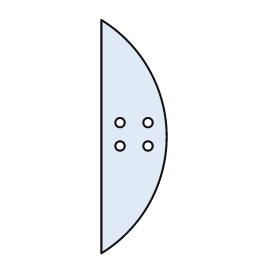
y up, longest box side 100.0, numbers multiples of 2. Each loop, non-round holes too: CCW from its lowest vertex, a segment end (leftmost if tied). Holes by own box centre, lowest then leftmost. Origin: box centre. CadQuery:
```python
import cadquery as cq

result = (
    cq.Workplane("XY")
    .moveTo(-14.0, -50.0)
    .threePointArc((14.0, 0.0), (-14.0, 50.0))
    .close()
    .moveTo(-6.0, -4.0)
    .circle(2.0)
    .moveTo(6.0, -4.0)
    .circle(2.0)
    .moveTo(-6.0, 6.0)
    .circle(2.0)
    .moveTo(6.0, 6.0)
    .circle(2.0)
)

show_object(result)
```